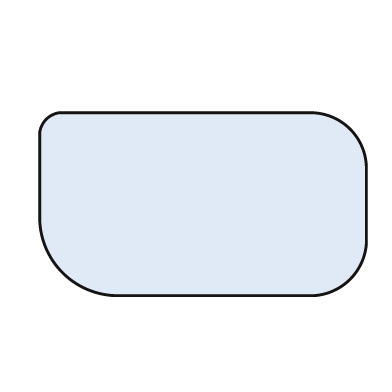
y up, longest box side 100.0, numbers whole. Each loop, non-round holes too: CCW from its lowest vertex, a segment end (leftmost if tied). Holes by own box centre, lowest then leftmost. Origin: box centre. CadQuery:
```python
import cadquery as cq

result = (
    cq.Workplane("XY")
    .moveTo(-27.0, -28.0)
    .lineTo(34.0, -28.0)
    .threePointArc((45.0, -23.0), (50.0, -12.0))
    .lineTo(50.0, 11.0)
    .threePointArc((45.0, 23.0), (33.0, 28.0))
    .lineTo(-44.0, 28.0)
    .threePointArc((-48.0, 26.0), (-50.0, 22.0))
    .lineTo(-50.0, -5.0)
    .threePointArc((-43.0, -21.0), (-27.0, -28.0))
    .close()
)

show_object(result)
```